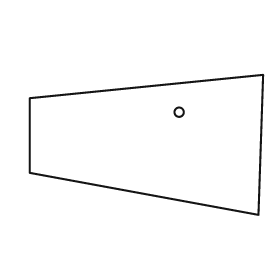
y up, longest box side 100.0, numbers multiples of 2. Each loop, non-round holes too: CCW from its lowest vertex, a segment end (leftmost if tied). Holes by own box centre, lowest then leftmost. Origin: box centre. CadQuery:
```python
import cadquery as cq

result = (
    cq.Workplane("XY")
    .moveTo(48.0, -30.0)
    .lineTo(50.0, 30.0)
    .lineTo(-50.0, 20.0)
    .lineTo(-50.0, -12.0)
    .close()
    .moveTo(14.0, 14.0)
    .circle(2.0)
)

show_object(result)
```